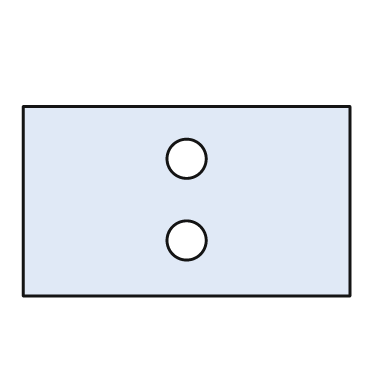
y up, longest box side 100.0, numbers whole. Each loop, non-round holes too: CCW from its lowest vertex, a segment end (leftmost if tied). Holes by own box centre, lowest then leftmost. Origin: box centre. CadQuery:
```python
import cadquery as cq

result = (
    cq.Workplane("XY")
    .moveTo(-50.0, -29.0)
    .lineTo(50.0, -29.0)
    .lineTo(50.0, 29.0)
    .lineTo(-50.0, 29.0)
    .close()
    .moveTo(0.0, -12.0)
    .circle(6.0)
    .moveTo(0.0, 13.0)
    .circle(6.0)
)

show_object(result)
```